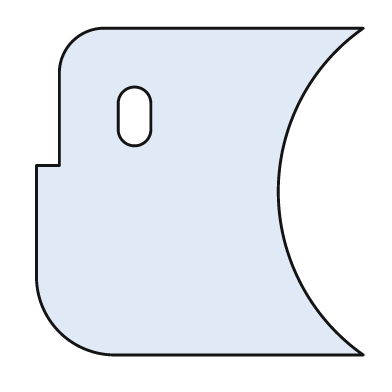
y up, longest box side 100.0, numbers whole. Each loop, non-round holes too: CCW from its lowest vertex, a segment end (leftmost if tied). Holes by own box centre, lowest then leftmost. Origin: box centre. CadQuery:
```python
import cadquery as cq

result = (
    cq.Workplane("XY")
    .moveTo(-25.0, -50.0)
    .lineTo(50.0, -50.0)
    .threePointArc((24.0, 0.0), (50.0, 50.0))
    .lineTo(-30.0, 50.0)
    .threePointArc((-39.0, 46.0), (-43.0, 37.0))
    .lineTo(-43.0, 8.0)
    .lineTo(-50.0, 8.0)
    .lineTo(-50.0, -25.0)
    .threePointArc((-43.0, -43.0), (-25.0, -50.0))
    .close()
    .moveTo(-25.0, 19.0)
    .threePointArc((-20.0, 14.0), (-15.0, 19.0))
    .lineTo(-15.0, 27.0)
    .threePointArc((-20.0, 32.0), (-25.0, 27.0))
    .close()
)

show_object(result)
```